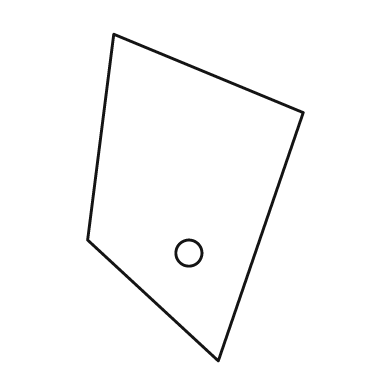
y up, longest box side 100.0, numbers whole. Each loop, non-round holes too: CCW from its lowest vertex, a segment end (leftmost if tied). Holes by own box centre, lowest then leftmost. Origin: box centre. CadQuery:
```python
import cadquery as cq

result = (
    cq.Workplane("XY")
    .moveTo(7.0, -50.0)
    .lineTo(33.0, 26.0)
    .lineTo(-25.0, 50.0)
    .lineTo(-33.0, -13.0)
    .close()
    .moveTo(-2.0, -17.0)
    .circle(4.0)
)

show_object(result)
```